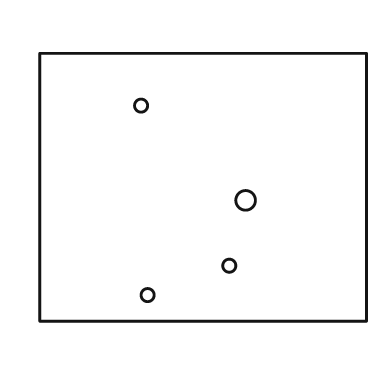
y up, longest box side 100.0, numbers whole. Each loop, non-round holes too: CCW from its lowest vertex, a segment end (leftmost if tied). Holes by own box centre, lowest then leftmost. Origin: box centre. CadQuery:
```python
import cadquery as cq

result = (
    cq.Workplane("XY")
    .moveTo(-50.0, -41.0)
    .lineTo(50.0, -41.0)
    .lineTo(50.0, 41.0)
    .lineTo(-50.0, 41.0)
    .close()
    .moveTo(-17.0, -33.0)
    .circle(2.0)
    .moveTo(8.0, -24.0)
    .circle(2.0)
    .moveTo(13.0, -4.0)
    .circle(3.0)
    .moveTo(-19.0, 25.0)
    .circle(2.0)
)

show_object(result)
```